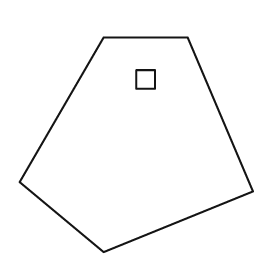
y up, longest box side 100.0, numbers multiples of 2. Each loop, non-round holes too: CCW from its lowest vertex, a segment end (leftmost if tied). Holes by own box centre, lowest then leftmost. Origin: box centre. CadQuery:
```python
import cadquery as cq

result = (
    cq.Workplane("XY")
    .moveTo(-14.0, -46.0)
    .lineTo(50.0, -20.0)
    .lineTo(22.0, 46.0)
    .lineTo(-14.0, 46.0)
    .lineTo(-50.0, -16.0)
    .close()
    .moveTo(0.0, 24.0)
    .lineTo(8.0, 24.0)
    .lineTo(8.0, 32.0)
    .lineTo(0.0, 32.0)
    .close()
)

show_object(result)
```